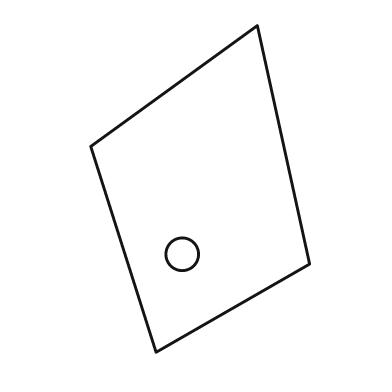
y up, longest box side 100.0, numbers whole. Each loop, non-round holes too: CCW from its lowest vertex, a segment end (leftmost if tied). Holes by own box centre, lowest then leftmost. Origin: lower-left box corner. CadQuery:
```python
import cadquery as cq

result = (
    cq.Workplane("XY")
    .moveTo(20.0, 0.0)
    .lineTo(67.0, 27.0)
    .lineTo(51.0, 100.0)
    .lineTo(0.0, 63.0)
    .close()
    .moveTo(28.0, 30.0)
    .circle(5.0)
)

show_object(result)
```